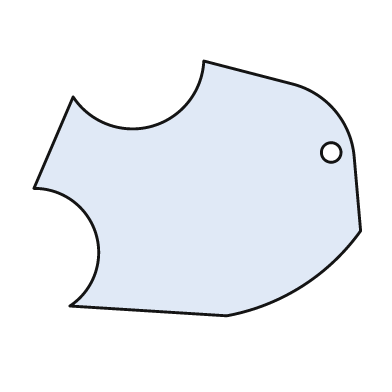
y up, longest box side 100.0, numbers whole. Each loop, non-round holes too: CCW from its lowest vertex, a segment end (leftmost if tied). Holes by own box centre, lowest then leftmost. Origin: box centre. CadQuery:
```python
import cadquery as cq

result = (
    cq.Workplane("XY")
    .moveTo(9.0, -39.0)
    .threePointArc((32.0, -30.0), (50.0, -13.0))
    .lineTo(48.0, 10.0)
    .threePointArc((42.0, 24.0), (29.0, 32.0))
    .lineTo(2.0, 39.0)
    .threePointArc((-14.0, 19.0), (-38.0, 28.0))
    .lineTo(-50.0, 0.0)
    .threePointArc((-31.0, -14.0), (-39.0, -36.0))
    .close()
    .moveTo(41.0, 11.0)
    .circle(3.0)
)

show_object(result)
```